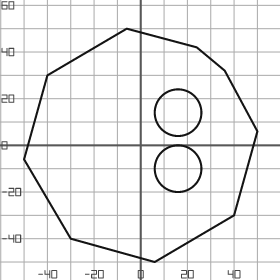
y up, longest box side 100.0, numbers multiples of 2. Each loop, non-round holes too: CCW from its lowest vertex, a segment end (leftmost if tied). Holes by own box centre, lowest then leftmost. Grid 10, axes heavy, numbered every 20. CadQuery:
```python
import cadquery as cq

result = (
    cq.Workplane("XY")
    .moveTo(6.0, -50.0)
    .lineTo(40.0, -30.0)
    .lineTo(50.0, 6.0)
    .lineTo(36.0, 32.0)
    .lineTo(24.0, 42.0)
    .lineTo(-6.0, 50.0)
    .lineTo(-40.0, 30.0)
    .lineTo(-50.0, -6.0)
    .lineTo(-30.0, -40.0)
    .close()
    .moveTo(16.0, -10.0)
    .circle(10.0)
    .moveTo(16.0, 14.0)
    .circle(10.0)
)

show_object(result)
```